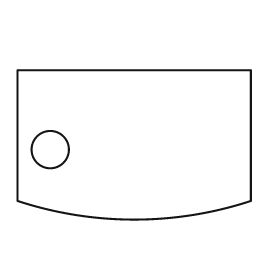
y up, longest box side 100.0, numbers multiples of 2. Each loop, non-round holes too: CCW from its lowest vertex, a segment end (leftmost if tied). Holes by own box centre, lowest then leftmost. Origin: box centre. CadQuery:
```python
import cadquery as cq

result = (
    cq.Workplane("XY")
    .moveTo(-50.0, -24.0)
    .threePointArc((0.0, -32.0), (50.0, -24.0))
    .lineTo(50.0, 32.0)
    .lineTo(-50.0, 32.0)
    .close()
    .moveTo(-36.0, -2.0)
    .circle(8.0)
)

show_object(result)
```